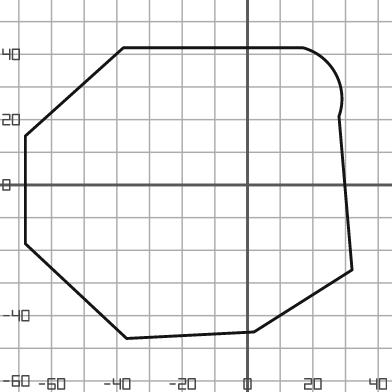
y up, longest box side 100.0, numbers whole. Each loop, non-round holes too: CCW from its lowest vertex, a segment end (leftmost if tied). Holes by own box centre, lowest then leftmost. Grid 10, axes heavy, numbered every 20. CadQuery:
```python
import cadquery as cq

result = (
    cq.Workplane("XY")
    .moveTo(-37.0, -47.0)
    .lineTo(2.0, -45.0)
    .lineTo(32.0, -26.0)
    .lineTo(28.0, 21.0)
    .threePointArc((27.0, 34.0), (17.0, 42.0))
    .lineTo(-38.0, 42.0)
    .lineTo(-68.0, 15.0)
    .lineTo(-68.0, -18.0)
    .close()
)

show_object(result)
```